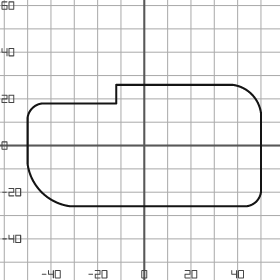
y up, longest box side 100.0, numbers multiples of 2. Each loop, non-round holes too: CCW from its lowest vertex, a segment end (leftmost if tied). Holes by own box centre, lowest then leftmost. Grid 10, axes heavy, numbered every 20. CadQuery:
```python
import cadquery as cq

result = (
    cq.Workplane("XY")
    .moveTo(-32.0, -26.0)
    .lineTo(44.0, -26.0)
    .threePointArc((48.0, -24.0), (50.0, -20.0))
    .lineTo(50.0, 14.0)
    .threePointArc((46.0, 22.0), (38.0, 26.0))
    .lineTo(-12.0, 26.0)
    .lineTo(-12.0, 18.0)
    .lineTo(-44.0, 18.0)
    .threePointArc((-48.0, 16.0), (-50.0, 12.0))
    .lineTo(-50.0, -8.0)
    .threePointArc((-44.0, -20.0), (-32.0, -26.0))
    .close()
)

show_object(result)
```